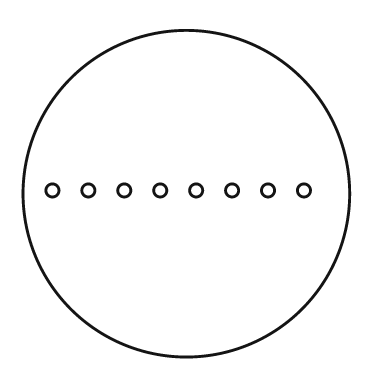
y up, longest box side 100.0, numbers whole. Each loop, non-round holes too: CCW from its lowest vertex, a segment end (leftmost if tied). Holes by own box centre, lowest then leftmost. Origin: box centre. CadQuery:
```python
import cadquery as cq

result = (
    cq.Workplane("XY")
    .moveTo(0.0, 0.0)
    .circle(50.0)
    .moveTo(-41.0, 1.0)
    .circle(2.0)
    .moveTo(-30.0, 1.0)
    .circle(2.0)
    .moveTo(-19.0, 1.0)
    .circle(2.0)
    .moveTo(-8.0, 1.0)
    .circle(2.0)
    .moveTo(3.0, 1.0)
    .circle(2.0)
    .moveTo(14.0, 1.0)
    .circle(2.0)
    .moveTo(25.0, 1.0)
    .circle(2.0)
    .moveTo(36.0, 1.0)
    .circle(2.0)
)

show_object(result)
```